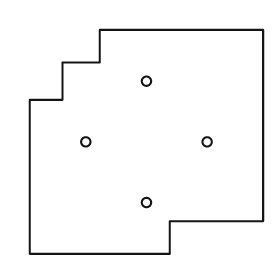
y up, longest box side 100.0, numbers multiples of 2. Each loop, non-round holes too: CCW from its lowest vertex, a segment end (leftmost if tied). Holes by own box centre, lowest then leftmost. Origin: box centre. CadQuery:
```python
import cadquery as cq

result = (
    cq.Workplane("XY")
    .moveTo(-50.0, -48.0)
    .lineTo(10.0, -48.0)
    .lineTo(10.0, -34.0)
    .lineTo(50.0, -34.0)
    .lineTo(50.0, 48.0)
    .lineTo(-20.0, 48.0)
    .lineTo(-20.0, 34.0)
    .lineTo(-36.0, 34.0)
    .lineTo(-36.0, 18.0)
    .lineTo(-50.0, 18.0)
    .close()
    .moveTo(0.0, -26.0)
    .circle(2.0)
    .moveTo(-26.0, 0.0)
    .circle(2.0)
    .moveTo(26.0, 0.0)
    .circle(2.0)
    .moveTo(0.0, 26.0)
    .circle(2.0)
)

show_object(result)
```